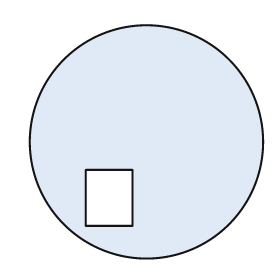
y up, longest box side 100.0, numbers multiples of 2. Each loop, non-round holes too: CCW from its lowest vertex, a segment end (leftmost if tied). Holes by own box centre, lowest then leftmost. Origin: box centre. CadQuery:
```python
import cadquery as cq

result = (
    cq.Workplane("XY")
    .moveTo(0.0, 0.0)
    .circle(50.0)
    .moveTo(-26.0, -36.0)
    .lineTo(-6.0, -36.0)
    .lineTo(-6.0, -12.0)
    .lineTo(-26.0, -12.0)
    .close()
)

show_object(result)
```